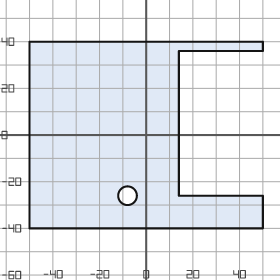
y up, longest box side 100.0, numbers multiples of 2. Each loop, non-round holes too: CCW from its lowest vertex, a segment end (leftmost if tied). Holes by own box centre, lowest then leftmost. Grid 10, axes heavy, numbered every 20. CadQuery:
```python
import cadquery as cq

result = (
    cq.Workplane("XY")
    .moveTo(-50.0, -40.0)
    .lineTo(50.0, -40.0)
    .lineTo(50.0, -26.0)
    .lineTo(14.0, -26.0)
    .lineTo(14.0, 36.0)
    .lineTo(50.0, 36.0)
    .lineTo(50.0, 40.0)
    .lineTo(-50.0, 40.0)
    .close()
    .moveTo(-8.0, -26.0)
    .circle(4.0)
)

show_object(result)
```